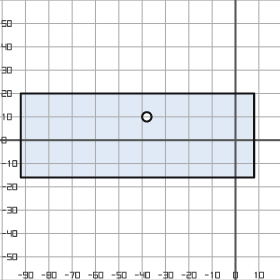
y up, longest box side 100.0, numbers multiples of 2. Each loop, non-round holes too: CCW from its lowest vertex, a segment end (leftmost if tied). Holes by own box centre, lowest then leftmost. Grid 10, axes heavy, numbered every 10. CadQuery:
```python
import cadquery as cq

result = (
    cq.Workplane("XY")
    .moveTo(-92.0, -16.0)
    .lineTo(8.0, -16.0)
    .lineTo(8.0, 20.0)
    .lineTo(-92.0, 20.0)
    .close()
    .moveTo(-38.0, 10.0)
    .circle(2.0)
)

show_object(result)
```